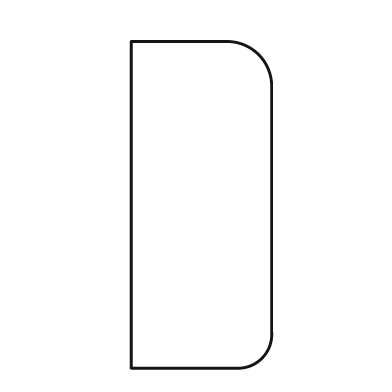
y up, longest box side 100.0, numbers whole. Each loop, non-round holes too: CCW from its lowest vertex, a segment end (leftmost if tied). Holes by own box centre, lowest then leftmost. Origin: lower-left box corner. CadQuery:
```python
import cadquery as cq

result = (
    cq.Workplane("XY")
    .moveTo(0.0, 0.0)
    .lineTo(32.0, 0.0)
    .threePointArc((40.0, 3.0), (43.0, 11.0))
    .lineTo(43.0, 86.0)
    .threePointArc((39.0, 96.0), (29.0, 100.0))
    .lineTo(0.0, 100.0)
    .close()
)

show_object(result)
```